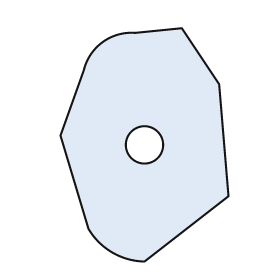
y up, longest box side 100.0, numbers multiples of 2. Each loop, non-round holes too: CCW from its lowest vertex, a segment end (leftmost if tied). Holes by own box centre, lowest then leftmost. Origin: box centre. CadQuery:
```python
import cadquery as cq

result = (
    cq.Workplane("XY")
    .moveTo(0.0, -50.0)
    .lineTo(36.0, -22.0)
    .lineTo(32.0, 26.0)
    .lineTo(16.0, 50.0)
    .lineTo(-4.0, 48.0)
    .threePointArc((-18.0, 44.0), (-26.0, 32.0))
    .lineTo(-36.0, 4.0)
    .lineTo(-24.0, -36.0)
    .threePointArc((-14.0, -46.0), (0.0, -50.0))
    .close()
    .moveTo(0.0, 0.0)
    .circle(8.0)
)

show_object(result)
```